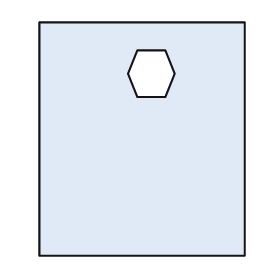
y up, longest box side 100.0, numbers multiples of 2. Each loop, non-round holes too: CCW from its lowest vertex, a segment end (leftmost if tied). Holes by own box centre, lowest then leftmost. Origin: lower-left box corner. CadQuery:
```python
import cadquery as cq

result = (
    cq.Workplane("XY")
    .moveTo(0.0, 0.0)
    .lineTo(88.0, 0.0)
    .lineTo(88.0, 100.0)
    .lineTo(0.0, 100.0)
    .close()
    .moveTo(42.0, 68.0)
    .lineTo(54.0, 68.0)
    .lineTo(58.0, 78.0)
    .lineTo(54.0, 88.0)
    .lineTo(42.0, 88.0)
    .lineTo(38.0, 78.0)
    .close()
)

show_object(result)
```